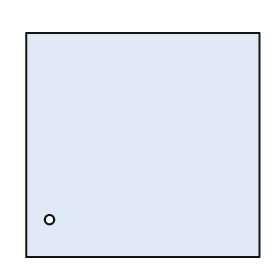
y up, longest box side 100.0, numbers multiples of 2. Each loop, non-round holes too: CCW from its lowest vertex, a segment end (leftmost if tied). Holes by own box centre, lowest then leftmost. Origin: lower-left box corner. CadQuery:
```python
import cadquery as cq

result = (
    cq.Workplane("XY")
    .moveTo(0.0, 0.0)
    .lineTo(100.0, 0.0)
    .lineTo(100.0, 96.0)
    .lineTo(0.0, 96.0)
    .close()
    .moveTo(10.0, 16.0)
    .circle(2.0)
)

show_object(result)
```